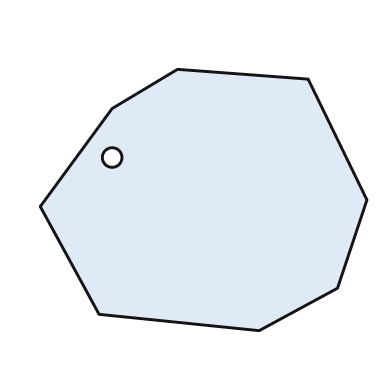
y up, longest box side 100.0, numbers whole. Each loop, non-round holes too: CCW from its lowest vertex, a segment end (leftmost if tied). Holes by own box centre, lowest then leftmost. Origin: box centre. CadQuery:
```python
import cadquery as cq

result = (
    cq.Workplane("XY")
    .moveTo(17.0, -40.0)
    .lineTo(41.0, -27.0)
    .lineTo(50.0, 0.0)
    .lineTo(32.0, 37.0)
    .lineTo(-8.0, 40.0)
    .lineTo(-28.0, 28.0)
    .lineTo(-50.0, -2.0)
    .lineTo(-32.0, -35.0)
    .close()
    .moveTo(-28.0, 13.0)
    .circle(3.0)
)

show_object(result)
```